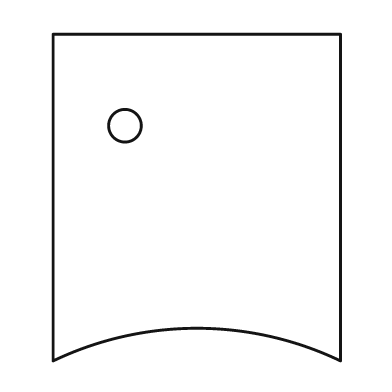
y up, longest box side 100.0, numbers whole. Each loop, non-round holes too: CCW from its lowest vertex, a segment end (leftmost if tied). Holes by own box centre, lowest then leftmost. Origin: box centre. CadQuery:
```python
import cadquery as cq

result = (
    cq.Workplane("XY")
    .moveTo(-44.0, -50.0)
    .threePointArc((0.0, -40.0), (44.0, -50.0))
    .lineTo(44.0, 50.0)
    .lineTo(-44.0, 50.0)
    .close()
    .moveTo(-22.0, 22.0)
    .circle(5.0)
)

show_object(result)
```